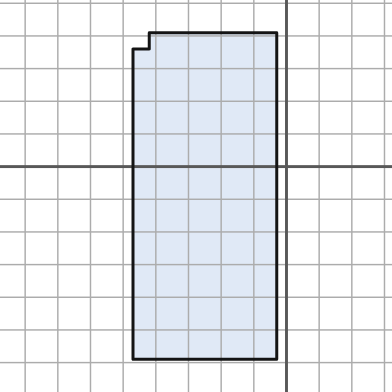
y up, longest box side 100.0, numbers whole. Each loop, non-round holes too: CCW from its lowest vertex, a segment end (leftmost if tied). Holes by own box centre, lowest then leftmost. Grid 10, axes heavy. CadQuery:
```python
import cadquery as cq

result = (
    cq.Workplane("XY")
    .moveTo(-47.0, -59.0)
    .lineTo(-3.0, -59.0)
    .lineTo(-3.0, 41.0)
    .lineTo(-42.0, 41.0)
    .lineTo(-42.0, 36.0)
    .lineTo(-47.0, 36.0)
    .close()
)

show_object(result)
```